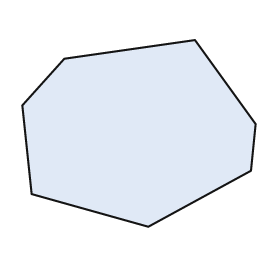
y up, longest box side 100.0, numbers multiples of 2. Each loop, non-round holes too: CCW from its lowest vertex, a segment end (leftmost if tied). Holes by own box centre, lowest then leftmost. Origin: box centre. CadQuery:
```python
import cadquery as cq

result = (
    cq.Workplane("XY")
    .moveTo(4.0, -40.0)
    .lineTo(48.0, -16.0)
    .lineTo(50.0, 4.0)
    .lineTo(24.0, 40.0)
    .lineTo(-32.0, 32.0)
    .lineTo(-50.0, 12.0)
    .lineTo(-46.0, -26.0)
    .close()
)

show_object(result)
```